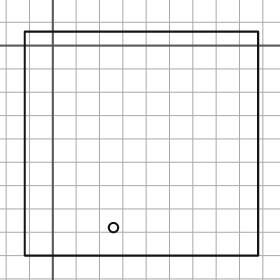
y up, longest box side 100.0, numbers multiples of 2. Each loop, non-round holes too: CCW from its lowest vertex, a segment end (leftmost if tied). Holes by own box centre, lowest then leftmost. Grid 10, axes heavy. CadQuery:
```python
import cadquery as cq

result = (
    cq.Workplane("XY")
    .moveTo(-12.0, -90.0)
    .lineTo(88.0, -90.0)
    .lineTo(88.0, 6.0)
    .lineTo(-12.0, 6.0)
    .close()
    .moveTo(26.0, -78.0)
    .circle(2.0)
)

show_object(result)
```